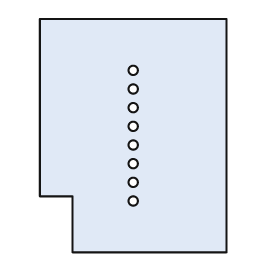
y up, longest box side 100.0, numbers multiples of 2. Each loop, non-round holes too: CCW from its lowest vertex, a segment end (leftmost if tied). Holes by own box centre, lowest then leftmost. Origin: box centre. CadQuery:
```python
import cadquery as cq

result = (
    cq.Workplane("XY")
    .moveTo(-26.0, -50.0)
    .lineTo(40.0, -50.0)
    .lineTo(40.0, 50.0)
    .lineTo(-40.0, 50.0)
    .lineTo(-40.0, -26.0)
    .lineTo(-26.0, -26.0)
    .close()
    .moveTo(0.0, -28.0)
    .circle(2.0)
    .moveTo(0.0, -20.0)
    .circle(2.0)
    .moveTo(0.0, -12.0)
    .circle(2.0)
    .moveTo(0.0, -4.0)
    .circle(2.0)
    .moveTo(0.0, 4.0)
    .circle(2.0)
    .moveTo(0.0, 12.0)
    .circle(2.0)
    .moveTo(0.0, 20.0)
    .circle(2.0)
    .moveTo(0.0, 28.0)
    .circle(2.0)
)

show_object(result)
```